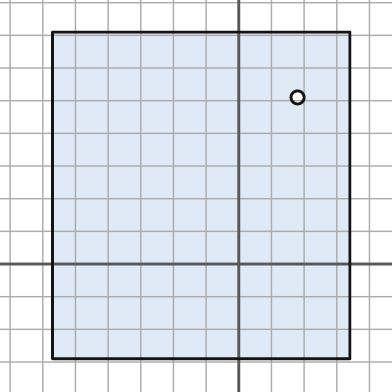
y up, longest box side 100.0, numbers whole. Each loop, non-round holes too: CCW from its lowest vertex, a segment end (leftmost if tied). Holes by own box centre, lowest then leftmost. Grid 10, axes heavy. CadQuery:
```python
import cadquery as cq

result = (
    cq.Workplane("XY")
    .moveTo(-57.0, -29.0)
    .lineTo(34.0, -29.0)
    .lineTo(34.0, 71.0)
    .lineTo(-57.0, 71.0)
    .close()
    .moveTo(18.0, 51.0)
    .circle(2.0)
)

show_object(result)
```